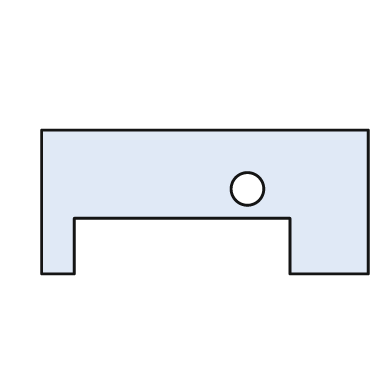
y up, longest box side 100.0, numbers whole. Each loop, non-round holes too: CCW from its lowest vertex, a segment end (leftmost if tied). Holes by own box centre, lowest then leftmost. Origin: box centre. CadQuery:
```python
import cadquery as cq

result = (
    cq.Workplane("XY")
    .moveTo(-50.0, -22.0)
    .lineTo(-40.0, -22.0)
    .lineTo(-40.0, -5.0)
    .lineTo(26.0, -5.0)
    .lineTo(26.0, -22.0)
    .lineTo(50.0, -22.0)
    .lineTo(50.0, 22.0)
    .lineTo(-50.0, 22.0)
    .close()
    .moveTo(13.0, 4.0)
    .circle(5.0)
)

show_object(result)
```